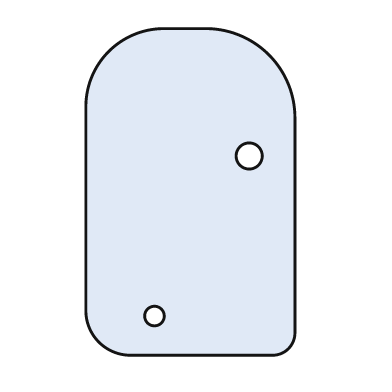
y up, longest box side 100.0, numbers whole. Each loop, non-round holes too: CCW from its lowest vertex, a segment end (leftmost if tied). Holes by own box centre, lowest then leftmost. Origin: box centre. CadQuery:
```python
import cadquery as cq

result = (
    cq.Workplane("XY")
    .moveTo(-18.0, -50.0)
    .lineTo(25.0, -50.0)
    .threePointArc((30.0, -48.0), (32.0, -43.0))
    .lineTo(32.0, 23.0)
    .threePointArc((24.0, 42.0), (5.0, 50.0))
    .lineTo(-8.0, 50.0)
    .threePointArc((-25.0, 43.0), (-32.0, 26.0))
    .lineTo(-32.0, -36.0)
    .threePointArc((-28.0, -46.0), (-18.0, -50.0))
    .close()
    .moveTo(-11.0, -38.0)
    .circle(3.0)
    .moveTo(18.0, 11.0)
    .circle(4.0)
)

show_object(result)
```